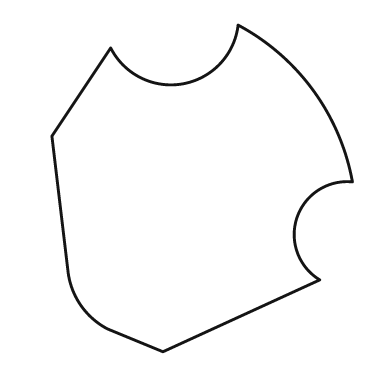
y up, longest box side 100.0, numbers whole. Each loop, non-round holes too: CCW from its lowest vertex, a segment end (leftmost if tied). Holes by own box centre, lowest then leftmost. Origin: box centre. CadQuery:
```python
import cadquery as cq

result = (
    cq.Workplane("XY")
    .moveTo(-12.0, -50.0)
    .lineTo(36.0, -28.0)
    .threePointArc((29.0, -9.0), (46.0, 2.0))
    .threePointArc((34.0, 30.0), (11.0, 50.0))
    .threePointArc((-6.0, 32.0), (-28.0, 43.0))
    .lineTo(-46.0, 16.0)
    .lineTo(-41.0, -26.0)
    .threePointArc((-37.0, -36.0), (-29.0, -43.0))
    .close()
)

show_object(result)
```